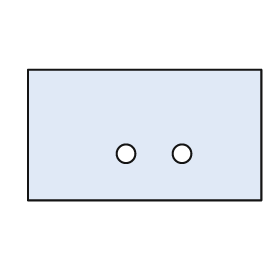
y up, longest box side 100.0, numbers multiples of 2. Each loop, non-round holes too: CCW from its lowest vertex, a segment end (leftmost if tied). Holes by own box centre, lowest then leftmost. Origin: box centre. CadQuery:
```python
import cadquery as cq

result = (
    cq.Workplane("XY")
    .moveTo(-50.0, -28.0)
    .lineTo(50.0, -28.0)
    .lineTo(50.0, 28.0)
    .lineTo(-50.0, 28.0)
    .close()
    .moveTo(-8.0, -8.0)
    .circle(4.0)
    .moveTo(16.0, -8.0)
    .circle(4.0)
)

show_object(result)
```